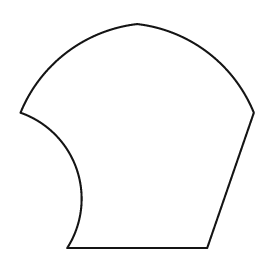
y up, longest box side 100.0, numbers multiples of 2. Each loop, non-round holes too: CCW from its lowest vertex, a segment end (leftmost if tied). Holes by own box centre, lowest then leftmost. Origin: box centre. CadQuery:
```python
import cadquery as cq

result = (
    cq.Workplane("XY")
    .moveTo(-30.0, -48.0)
    .lineTo(30.0, -48.0)
    .lineTo(50.0, 10.0)
    .threePointArc((30.0, 36.0), (0.0, 48.0))
    .threePointArc((-30.0, 36.0), (-50.0, 10.0))
    .threePointArc((-26.0, -14.0), (-30.0, -48.0))
    .close()
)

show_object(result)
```